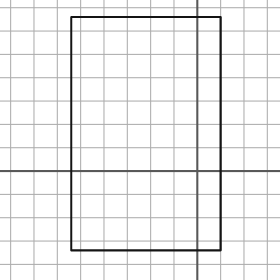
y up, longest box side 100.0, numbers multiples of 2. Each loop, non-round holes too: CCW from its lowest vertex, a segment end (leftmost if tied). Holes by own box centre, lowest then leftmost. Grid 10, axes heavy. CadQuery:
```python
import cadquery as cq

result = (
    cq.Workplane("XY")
    .moveTo(-54.0, -34.0)
    .lineTo(10.0, -34.0)
    .lineTo(10.0, 66.0)
    .lineTo(-54.0, 66.0)
    .close()
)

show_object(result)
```